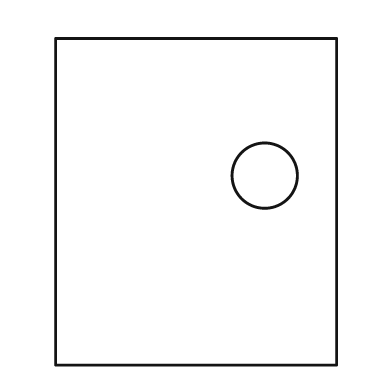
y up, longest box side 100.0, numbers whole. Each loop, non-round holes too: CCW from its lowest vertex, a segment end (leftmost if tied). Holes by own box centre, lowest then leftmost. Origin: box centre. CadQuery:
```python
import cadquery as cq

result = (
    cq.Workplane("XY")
    .moveTo(-43.0, -50.0)
    .lineTo(43.0, -50.0)
    .lineTo(43.0, 50.0)
    .lineTo(-43.0, 50.0)
    .close()
    .moveTo(21.0, 8.0)
    .circle(10.0)
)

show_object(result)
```